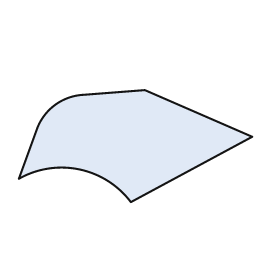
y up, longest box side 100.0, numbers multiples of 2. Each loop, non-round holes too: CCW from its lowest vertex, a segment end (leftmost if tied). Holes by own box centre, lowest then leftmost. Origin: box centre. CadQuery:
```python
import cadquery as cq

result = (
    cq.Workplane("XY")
    .moveTo(-2.0, -24.0)
    .lineTo(50.0, 4.0)
    .lineTo(4.0, 24.0)
    .lineTo(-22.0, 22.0)
    .threePointArc((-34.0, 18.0), (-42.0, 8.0))
    .lineTo(-50.0, -14.0)
    .threePointArc((-24.0, -10.0), (-2.0, -24.0))
    .close()
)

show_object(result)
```